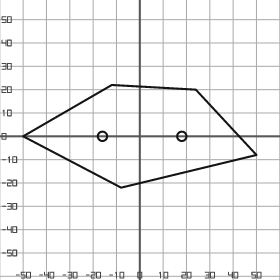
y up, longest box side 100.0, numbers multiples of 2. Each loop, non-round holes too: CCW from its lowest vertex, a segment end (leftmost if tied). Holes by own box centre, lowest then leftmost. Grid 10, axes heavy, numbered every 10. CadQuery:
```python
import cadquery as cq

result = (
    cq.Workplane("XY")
    .moveTo(-8.0, -22.0)
    .lineTo(50.0, -8.0)
    .lineTo(24.0, 20.0)
    .lineTo(-12.0, 22.0)
    .lineTo(-50.0, 0.0)
    .close()
    .moveTo(-16.0, 0.0)
    .circle(2.0)
    .moveTo(18.0, 0.0)
    .circle(2.0)
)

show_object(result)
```